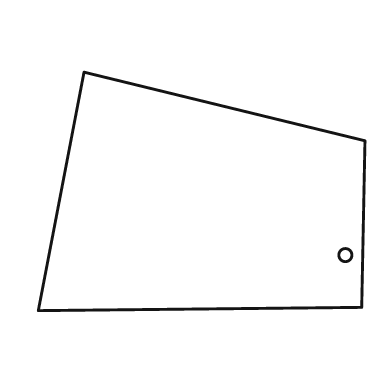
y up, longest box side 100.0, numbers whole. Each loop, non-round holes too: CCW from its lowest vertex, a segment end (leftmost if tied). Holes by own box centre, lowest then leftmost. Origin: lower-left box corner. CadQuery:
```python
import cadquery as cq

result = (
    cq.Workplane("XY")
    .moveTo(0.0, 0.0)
    .lineTo(99.0, 1.0)
    .lineTo(100.0, 52.0)
    .lineTo(14.0, 73.0)
    .close()
    .moveTo(94.0, 17.0)
    .circle(2.0)
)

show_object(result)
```